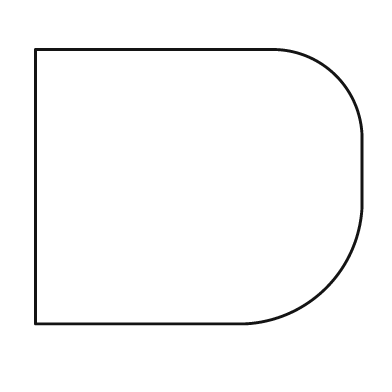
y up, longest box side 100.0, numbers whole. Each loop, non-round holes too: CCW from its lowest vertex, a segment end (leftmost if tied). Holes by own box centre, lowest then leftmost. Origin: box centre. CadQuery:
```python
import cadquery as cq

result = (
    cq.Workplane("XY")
    .moveTo(-50.0, -42.0)
    .lineTo(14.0, -42.0)
    .threePointArc((39.0, -31.0), (50.0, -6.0))
    .lineTo(50.0, 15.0)
    .threePointArc((42.0, 34.0), (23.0, 42.0))
    .lineTo(-50.0, 42.0)
    .close()
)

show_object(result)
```